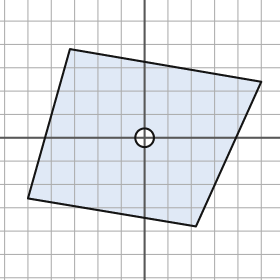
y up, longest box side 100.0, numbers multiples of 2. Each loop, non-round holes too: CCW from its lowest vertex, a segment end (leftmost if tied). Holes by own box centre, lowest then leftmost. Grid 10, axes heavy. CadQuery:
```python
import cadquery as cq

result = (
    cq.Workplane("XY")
    .moveTo(22.0, -38.0)
    .lineTo(50.0, 24.0)
    .lineTo(-32.0, 38.0)
    .lineTo(-50.0, -26.0)
    .close()
    .moveTo(0.0, 0.0)
    .circle(4.0)
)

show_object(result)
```